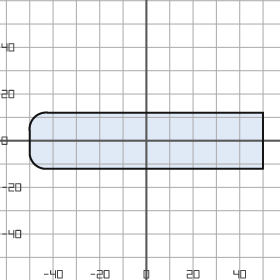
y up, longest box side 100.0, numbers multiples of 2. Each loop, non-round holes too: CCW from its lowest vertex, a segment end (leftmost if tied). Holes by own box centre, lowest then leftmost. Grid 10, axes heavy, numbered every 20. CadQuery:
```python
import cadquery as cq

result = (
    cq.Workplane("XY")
    .moveTo(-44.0, -12.0)
    .lineTo(50.0, -12.0)
    .lineTo(50.0, 12.0)
    .lineTo(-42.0, 12.0)
    .threePointArc((-48.0, 10.0), (-50.0, 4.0))
    .lineTo(-50.0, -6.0)
    .threePointArc((-48.0, -10.0), (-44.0, -12.0))
    .close()
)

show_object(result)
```